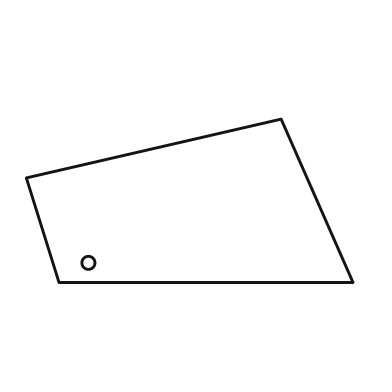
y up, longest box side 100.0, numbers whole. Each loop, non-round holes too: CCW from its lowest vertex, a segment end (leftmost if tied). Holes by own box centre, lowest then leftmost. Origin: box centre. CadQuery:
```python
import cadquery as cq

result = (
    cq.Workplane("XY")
    .moveTo(-40.0, -25.0)
    .lineTo(50.0, -25.0)
    .lineTo(28.0, 25.0)
    .lineTo(-50.0, 7.0)
    .close()
    .moveTo(-31.0, -19.0)
    .circle(2.0)
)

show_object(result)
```